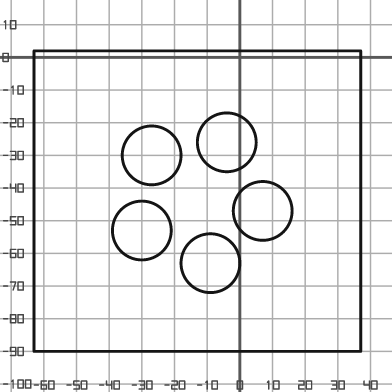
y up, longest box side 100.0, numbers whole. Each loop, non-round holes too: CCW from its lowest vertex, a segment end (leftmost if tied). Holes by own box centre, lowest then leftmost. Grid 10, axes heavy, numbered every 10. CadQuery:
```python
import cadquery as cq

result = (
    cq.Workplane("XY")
    .moveTo(-63.0, -90.0)
    .lineTo(37.0, -90.0)
    .lineTo(37.0, 2.0)
    .lineTo(-63.0, 2.0)
    .close()
    .moveTo(-9.0, -63.0)
    .circle(9.0)
    .moveTo(-30.0, -53.0)
    .circle(9.0)
    .moveTo(7.0, -47.0)
    .circle(9.0)
    .moveTo(-27.0, -30.0)
    .circle(9.0)
    .moveTo(-4.0, -26.0)
    .circle(9.0)
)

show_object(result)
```